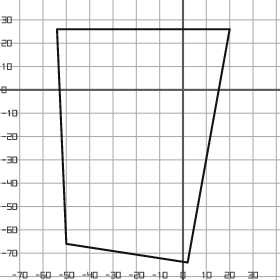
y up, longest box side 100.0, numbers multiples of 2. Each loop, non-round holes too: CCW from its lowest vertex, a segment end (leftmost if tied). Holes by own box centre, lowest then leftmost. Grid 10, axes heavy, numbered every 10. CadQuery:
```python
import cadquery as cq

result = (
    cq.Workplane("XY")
    .moveTo(2.0, -74.0)
    .lineTo(20.0, 26.0)
    .lineTo(-54.0, 26.0)
    .lineTo(-50.0, -66.0)
    .close()
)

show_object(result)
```